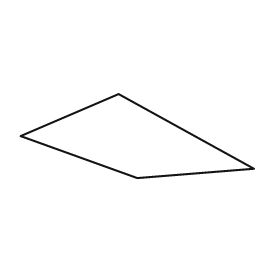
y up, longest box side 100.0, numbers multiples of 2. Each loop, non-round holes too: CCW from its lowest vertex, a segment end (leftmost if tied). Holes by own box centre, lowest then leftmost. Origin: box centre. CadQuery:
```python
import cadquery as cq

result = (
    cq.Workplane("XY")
    .moveTo(0.0, -18.0)
    .lineTo(50.0, -14.0)
    .lineTo(-8.0, 18.0)
    .lineTo(-50.0, 0.0)
    .close()
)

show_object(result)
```